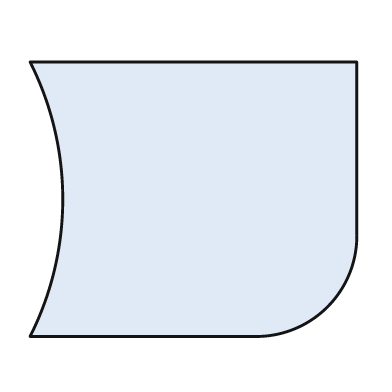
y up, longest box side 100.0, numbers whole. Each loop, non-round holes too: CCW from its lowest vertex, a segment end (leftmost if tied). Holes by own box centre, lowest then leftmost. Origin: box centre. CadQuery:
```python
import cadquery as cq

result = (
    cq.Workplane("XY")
    .moveTo(-50.0, -42.0)
    .lineTo(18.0, -42.0)
    .threePointArc((41.0, -33.0), (50.0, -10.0))
    .lineTo(50.0, 42.0)
    .lineTo(-50.0, 42.0)
    .threePointArc((-40.0, 0.0), (-50.0, -42.0))
    .close()
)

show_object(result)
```